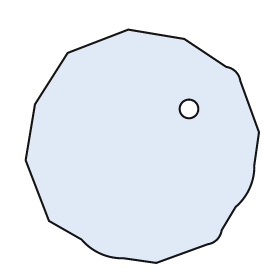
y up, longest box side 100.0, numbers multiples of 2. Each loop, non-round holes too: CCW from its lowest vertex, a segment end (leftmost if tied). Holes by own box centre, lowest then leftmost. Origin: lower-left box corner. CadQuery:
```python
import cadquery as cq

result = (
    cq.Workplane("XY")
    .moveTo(56.0, 0.0)
    .lineTo(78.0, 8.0)
    .threePointArc((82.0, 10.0), (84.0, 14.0))
    .lineTo(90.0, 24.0)
    .threePointArc((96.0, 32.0), (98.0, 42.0))
    .lineTo(100.0, 56.0)
    .lineTo(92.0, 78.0)
    .threePointArc((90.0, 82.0), (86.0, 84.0))
    .lineTo(68.0, 96.0)
    .lineTo(44.0, 100.0)
    .lineTo(18.0, 90.0)
    .lineTo(4.0, 68.0)
    .lineTo(0.0, 44.0)
    .lineTo(10.0, 18.0)
    .lineTo(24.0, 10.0)
    .threePointArc((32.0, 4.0), (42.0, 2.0))
    .close()
    .moveTo(70.0, 66.0)
    .circle(4.0)
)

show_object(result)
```